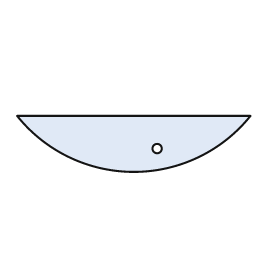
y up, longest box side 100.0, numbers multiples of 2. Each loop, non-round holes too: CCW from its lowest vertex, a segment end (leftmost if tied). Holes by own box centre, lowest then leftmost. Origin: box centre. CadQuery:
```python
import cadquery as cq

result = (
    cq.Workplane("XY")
    .moveTo(-50.0, 12.0)
    .threePointArc((0.0, -12.0), (50.0, 12.0))
    .close()
    .moveTo(10.0, -2.0)
    .circle(2.0)
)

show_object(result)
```